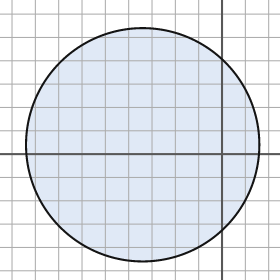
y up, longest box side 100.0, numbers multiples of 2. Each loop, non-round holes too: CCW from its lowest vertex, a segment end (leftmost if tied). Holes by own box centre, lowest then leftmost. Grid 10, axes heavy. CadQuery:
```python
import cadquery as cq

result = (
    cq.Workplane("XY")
    .moveTo(-34.0, 4.0)
    .circle(50.0)
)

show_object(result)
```